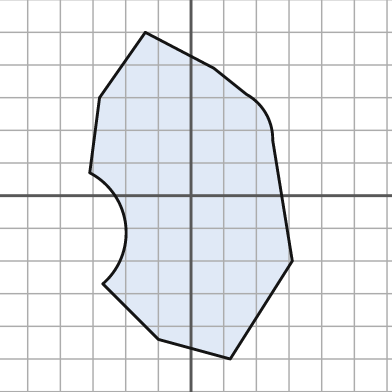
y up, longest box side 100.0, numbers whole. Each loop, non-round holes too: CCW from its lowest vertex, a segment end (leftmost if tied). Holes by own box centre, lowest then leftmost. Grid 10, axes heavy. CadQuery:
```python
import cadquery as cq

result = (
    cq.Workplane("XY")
    .moveTo(12.0, -50.0)
    .lineTo(31.0, -20.0)
    .lineTo(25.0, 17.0)
    .threePointArc((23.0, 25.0), (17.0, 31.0))
    .lineTo(7.0, 39.0)
    .lineTo(-14.0, 50.0)
    .lineTo(-28.0, 30.0)
    .lineTo(-31.0, 7.0)
    .threePointArc((-20.0, -9.0), (-27.0, -27.0))
    .lineTo(-10.0, -44.0)
    .close()
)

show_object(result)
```